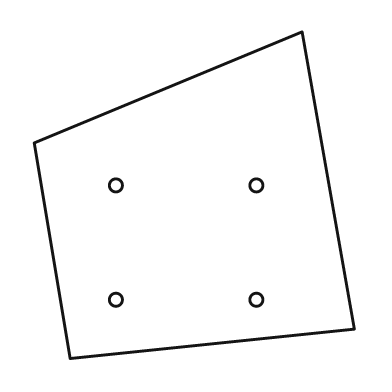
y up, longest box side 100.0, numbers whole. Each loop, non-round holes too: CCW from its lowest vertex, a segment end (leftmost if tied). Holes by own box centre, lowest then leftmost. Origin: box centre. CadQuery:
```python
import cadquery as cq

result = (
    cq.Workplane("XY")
    .moveTo(-38.0, -50.0)
    .lineTo(49.0, -41.0)
    .lineTo(33.0, 50.0)
    .lineTo(-49.0, 16.0)
    .close()
    .moveTo(-24.0, -32.0)
    .circle(2.0)
    .moveTo(19.0, -32.0)
    .circle(2.0)
    .moveTo(-24.0, 3.0)
    .circle(2.0)
    .moveTo(19.0, 3.0)
    .circle(2.0)
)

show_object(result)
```